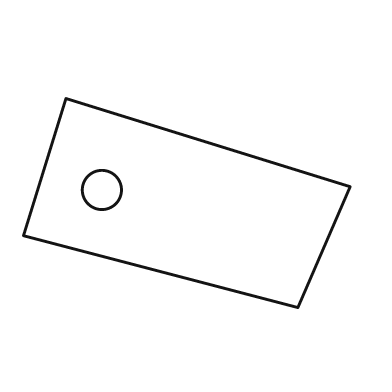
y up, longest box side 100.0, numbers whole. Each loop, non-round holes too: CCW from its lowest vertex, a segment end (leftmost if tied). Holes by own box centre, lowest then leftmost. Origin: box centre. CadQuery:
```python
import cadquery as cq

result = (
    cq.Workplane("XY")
    .moveTo(34.0, -32.0)
    .lineTo(50.0, 5.0)
    .lineTo(-37.0, 32.0)
    .lineTo(-50.0, -10.0)
    .close()
    .moveTo(-26.0, 4.0)
    .circle(6.0)
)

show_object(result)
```